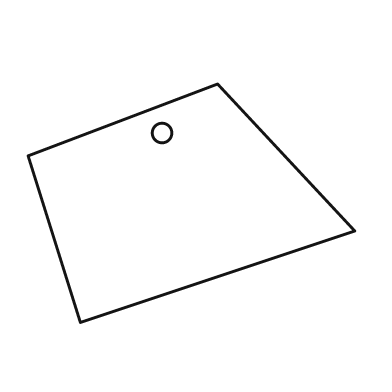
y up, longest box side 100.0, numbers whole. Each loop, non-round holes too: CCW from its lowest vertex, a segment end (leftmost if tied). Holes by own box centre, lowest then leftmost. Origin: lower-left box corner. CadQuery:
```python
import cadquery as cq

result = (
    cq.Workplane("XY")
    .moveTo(16.0, 0.0)
    .lineTo(100.0, 28.0)
    .lineTo(58.0, 73.0)
    .lineTo(0.0, 51.0)
    .close()
    .moveTo(41.0, 58.0)
    .circle(3.0)
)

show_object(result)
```